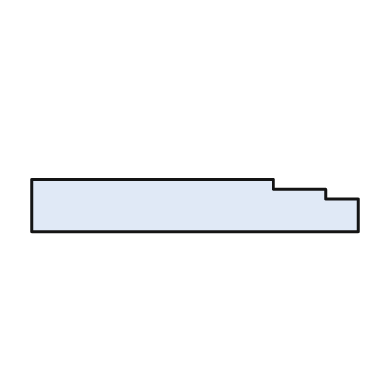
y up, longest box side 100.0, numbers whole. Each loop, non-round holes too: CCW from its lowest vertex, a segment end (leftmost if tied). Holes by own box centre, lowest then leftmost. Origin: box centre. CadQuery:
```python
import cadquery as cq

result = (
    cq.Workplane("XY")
    .moveTo(-50.0, -8.0)
    .lineTo(50.0, -8.0)
    .lineTo(50.0, 2.0)
    .lineTo(40.0, 2.0)
    .lineTo(40.0, 5.0)
    .lineTo(24.0, 5.0)
    .lineTo(24.0, 8.0)
    .lineTo(-50.0, 8.0)
    .close()
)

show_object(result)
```